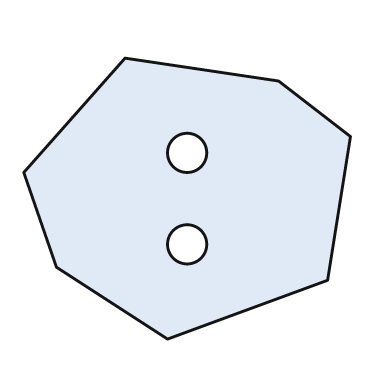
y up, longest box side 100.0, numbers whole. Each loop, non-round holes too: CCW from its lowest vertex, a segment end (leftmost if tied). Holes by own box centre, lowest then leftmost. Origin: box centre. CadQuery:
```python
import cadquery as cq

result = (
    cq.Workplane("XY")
    .moveTo(-6.0, -43.0)
    .lineTo(43.0, -25.0)
    .lineTo(50.0, 19.0)
    .lineTo(28.0, 36.0)
    .lineTo(-19.0, 43.0)
    .lineTo(-50.0, 8.0)
    .lineTo(-40.0, -21.0)
    .close()
    .moveTo(0.0, -14.0)
    .circle(6.0)
    .moveTo(0.0, 14.0)
    .circle(6.0)
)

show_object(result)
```